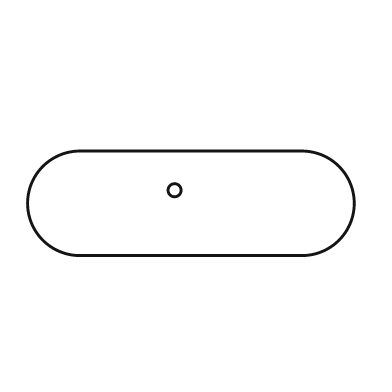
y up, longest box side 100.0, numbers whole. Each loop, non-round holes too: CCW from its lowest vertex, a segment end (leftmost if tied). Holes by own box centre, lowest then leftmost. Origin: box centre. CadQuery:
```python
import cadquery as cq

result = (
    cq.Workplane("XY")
    .moveTo(-34.0, -16.0)
    .lineTo(34.0, -16.0)
    .threePointArc((50.0, 0.0), (34.0, 16.0))
    .lineTo(-34.0, 16.0)
    .threePointArc((-50.0, 0.0), (-34.0, -16.0))
    .close()
    .moveTo(-5.0, 4.0)
    .circle(2.0)
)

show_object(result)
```